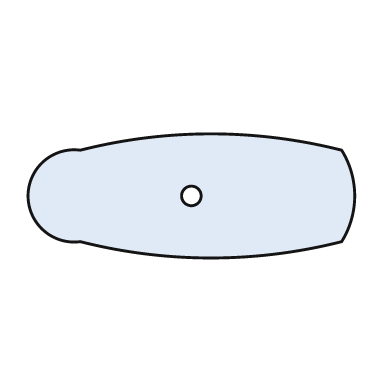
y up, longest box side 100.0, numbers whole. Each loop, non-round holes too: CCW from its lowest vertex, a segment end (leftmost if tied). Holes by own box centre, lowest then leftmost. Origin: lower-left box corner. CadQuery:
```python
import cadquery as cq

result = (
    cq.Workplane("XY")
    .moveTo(16.0, 5.0)
    .threePointArc((56.0, 0.0), (96.0, 5.0))
    .threePointArc((100.0, 19.0), (96.0, 33.0))
    .threePointArc((56.0, 38.0), (16.0, 33.0))
    .threePointArc((0.0, 19.0), (16.0, 5.0))
    .close()
    .moveTo(50.0, 19.0)
    .circle(3.0)
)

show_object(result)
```